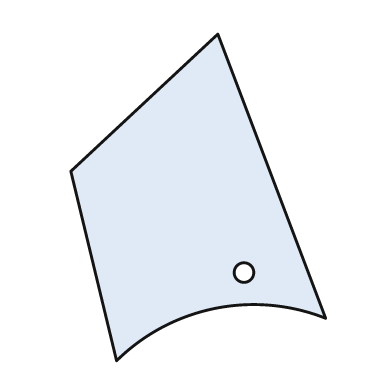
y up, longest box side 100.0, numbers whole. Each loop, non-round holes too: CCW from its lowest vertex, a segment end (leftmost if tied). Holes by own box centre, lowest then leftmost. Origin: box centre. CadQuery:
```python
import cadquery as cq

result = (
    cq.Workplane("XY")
    .moveTo(-25.0, -50.0)
    .threePointArc((5.0, -34.0), (39.0, -37.0))
    .lineTo(6.0, 50.0)
    .lineTo(-39.0, 8.0)
    .close()
    .moveTo(14.0, -23.0)
    .circle(3.0)
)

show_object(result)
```